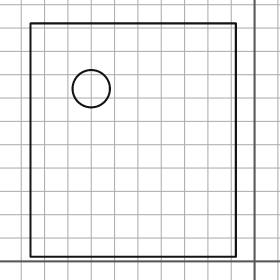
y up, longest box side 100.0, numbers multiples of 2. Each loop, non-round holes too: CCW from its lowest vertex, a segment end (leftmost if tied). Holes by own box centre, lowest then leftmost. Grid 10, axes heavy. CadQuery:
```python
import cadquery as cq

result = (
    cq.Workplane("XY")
    .moveTo(-96.0, 2.0)
    .lineTo(-8.0, 2.0)
    .lineTo(-8.0, 102.0)
    .lineTo(-96.0, 102.0)
    .close()
    .moveTo(-70.0, 74.0)
    .circle(8.0)
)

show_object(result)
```